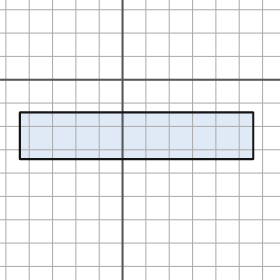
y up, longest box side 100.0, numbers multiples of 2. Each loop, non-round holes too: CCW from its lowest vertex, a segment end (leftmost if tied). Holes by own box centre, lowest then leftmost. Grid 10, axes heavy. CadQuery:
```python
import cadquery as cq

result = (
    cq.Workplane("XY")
    .moveTo(-44.0, -34.0)
    .lineTo(56.0, -34.0)
    .lineTo(56.0, -14.0)
    .lineTo(-44.0, -14.0)
    .close()
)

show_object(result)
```